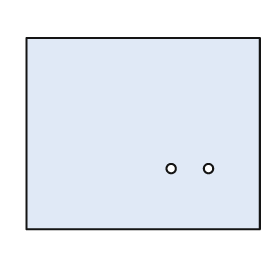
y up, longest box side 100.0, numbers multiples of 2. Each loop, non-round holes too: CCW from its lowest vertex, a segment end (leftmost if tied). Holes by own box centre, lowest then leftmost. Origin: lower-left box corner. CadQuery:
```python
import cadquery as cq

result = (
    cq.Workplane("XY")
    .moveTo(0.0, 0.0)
    .lineTo(100.0, 0.0)
    .lineTo(100.0, 82.0)
    .lineTo(0.0, 82.0)
    .close()
    .moveTo(62.0, 26.0)
    .circle(2.0)
    .moveTo(78.0, 26.0)
    .circle(2.0)
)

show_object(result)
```